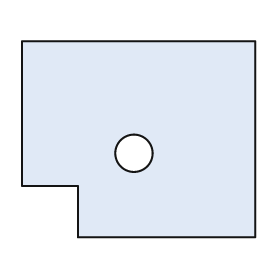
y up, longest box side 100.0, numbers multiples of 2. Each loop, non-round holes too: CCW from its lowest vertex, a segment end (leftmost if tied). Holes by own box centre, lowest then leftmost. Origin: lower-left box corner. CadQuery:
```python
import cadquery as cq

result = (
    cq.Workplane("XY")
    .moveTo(24.0, 0.0)
    .lineTo(100.0, 0.0)
    .lineTo(100.0, 84.0)
    .lineTo(0.0, 84.0)
    .lineTo(0.0, 22.0)
    .lineTo(24.0, 22.0)
    .close()
    .moveTo(48.0, 36.0)
    .circle(8.0)
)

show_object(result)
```